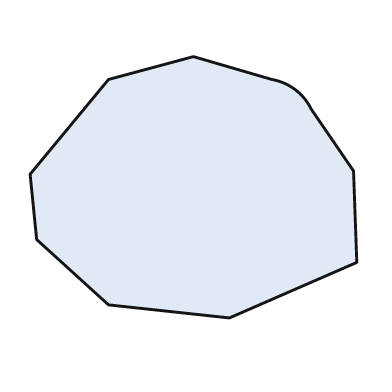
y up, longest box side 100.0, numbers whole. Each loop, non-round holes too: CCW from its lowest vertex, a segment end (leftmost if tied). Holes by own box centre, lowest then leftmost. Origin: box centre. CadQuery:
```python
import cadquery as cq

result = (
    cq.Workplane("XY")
    .moveTo(11.0, -40.0)
    .lineTo(50.0, -23.0)
    .lineTo(49.0, 5.0)
    .lineTo(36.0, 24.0)
    .threePointArc((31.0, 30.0), (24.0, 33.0))
    .lineTo(0.0, 40.0)
    .lineTo(-26.0, 33.0)
    .lineTo(-50.0, 4.0)
    .lineTo(-48.0, -16.0)
    .lineTo(-26.0, -36.0)
    .close()
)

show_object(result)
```